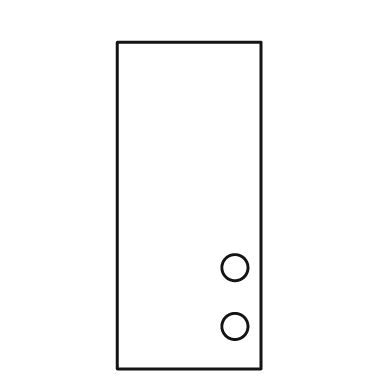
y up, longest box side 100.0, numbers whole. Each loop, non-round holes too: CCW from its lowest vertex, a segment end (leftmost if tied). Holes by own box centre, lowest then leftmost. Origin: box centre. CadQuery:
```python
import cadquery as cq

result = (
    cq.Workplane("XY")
    .moveTo(-22.0, -50.0)
    .lineTo(22.0, -50.0)
    .lineTo(22.0, 50.0)
    .lineTo(-22.0, 50.0)
    .close()
    .moveTo(14.0, -37.0)
    .circle(4.0)
    .moveTo(14.0, -19.0)
    .circle(4.0)
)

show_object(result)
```